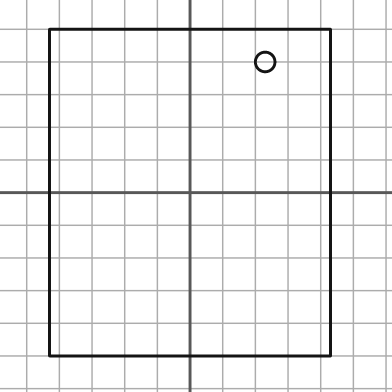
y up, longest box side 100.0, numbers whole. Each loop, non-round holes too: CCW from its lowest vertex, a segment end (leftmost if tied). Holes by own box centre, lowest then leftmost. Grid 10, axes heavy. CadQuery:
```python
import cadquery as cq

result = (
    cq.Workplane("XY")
    .moveTo(-43.0, -50.0)
    .lineTo(43.0, -50.0)
    .lineTo(43.0, 50.0)
    .lineTo(-43.0, 50.0)
    .close()
    .moveTo(23.0, 40.0)
    .circle(3.0)
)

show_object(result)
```